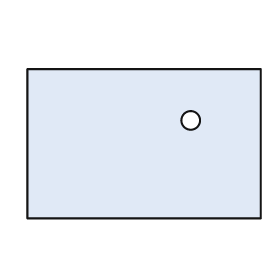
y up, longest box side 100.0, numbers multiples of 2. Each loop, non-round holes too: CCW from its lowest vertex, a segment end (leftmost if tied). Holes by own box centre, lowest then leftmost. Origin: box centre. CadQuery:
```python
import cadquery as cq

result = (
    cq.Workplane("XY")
    .moveTo(-50.0, -32.0)
    .lineTo(50.0, -32.0)
    .lineTo(50.0, 32.0)
    .lineTo(-50.0, 32.0)
    .close()
    .moveTo(20.0, 10.0)
    .circle(4.0)
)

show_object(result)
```